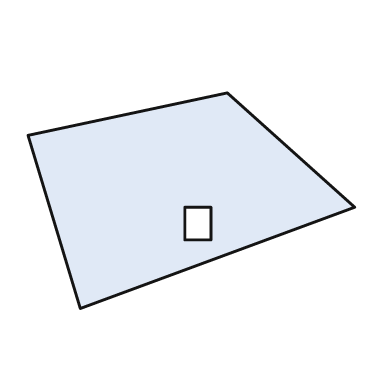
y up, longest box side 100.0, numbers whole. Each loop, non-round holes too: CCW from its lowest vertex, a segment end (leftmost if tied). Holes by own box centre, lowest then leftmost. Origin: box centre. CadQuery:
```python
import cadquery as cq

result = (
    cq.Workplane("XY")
    .moveTo(-34.0, -33.0)
    .lineTo(50.0, -2.0)
    .lineTo(11.0, 33.0)
    .lineTo(-50.0, 20.0)
    .close()
    .moveTo(-2.0, -12.0)
    .lineTo(6.0, -12.0)
    .lineTo(6.0, -2.0)
    .lineTo(-2.0, -2.0)
    .close()
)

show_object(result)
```